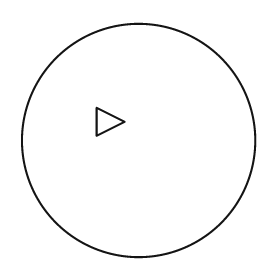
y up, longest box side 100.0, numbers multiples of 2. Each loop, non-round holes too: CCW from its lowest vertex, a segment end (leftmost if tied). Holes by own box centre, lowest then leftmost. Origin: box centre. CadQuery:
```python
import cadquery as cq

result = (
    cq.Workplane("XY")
    .moveTo(0.0, 0.0)
    .circle(50.0)
    .moveTo(-18.0, 2.0)
    .lineTo(-6.0, 8.0)
    .lineTo(-18.0, 14.0)
    .close()
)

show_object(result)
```